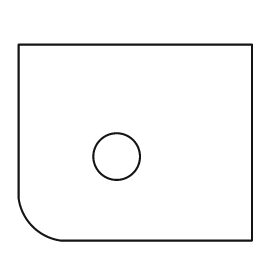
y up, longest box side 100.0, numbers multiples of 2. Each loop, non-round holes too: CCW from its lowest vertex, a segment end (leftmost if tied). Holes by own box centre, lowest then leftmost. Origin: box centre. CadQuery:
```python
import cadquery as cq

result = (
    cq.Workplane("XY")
    .moveTo(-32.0, -42.0)
    .lineTo(50.0, -42.0)
    .lineTo(50.0, 42.0)
    .lineTo(-50.0, 42.0)
    .lineTo(-50.0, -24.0)
    .threePointArc((-44.0, -36.0), (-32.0, -42.0))
    .close()
    .moveTo(-8.0, -6.0)
    .circle(10.0)
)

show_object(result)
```